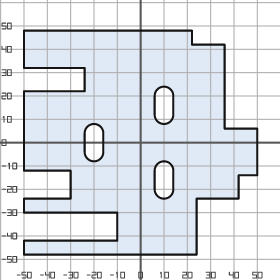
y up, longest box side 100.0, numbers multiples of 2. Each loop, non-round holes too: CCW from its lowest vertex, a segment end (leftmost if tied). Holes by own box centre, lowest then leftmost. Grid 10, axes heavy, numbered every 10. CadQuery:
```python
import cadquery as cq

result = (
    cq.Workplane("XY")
    .moveTo(-50.0, -48.0)
    .lineTo(24.0, -48.0)
    .lineTo(24.0, -24.0)
    .lineTo(42.0, -24.0)
    .lineTo(42.0, -14.0)
    .lineTo(50.0, -14.0)
    .lineTo(50.0, 6.0)
    .lineTo(36.0, 6.0)
    .lineTo(36.0, 42.0)
    .lineTo(22.0, 42.0)
    .lineTo(22.0, 48.0)
    .lineTo(-50.0, 48.0)
    .lineTo(-50.0, 32.0)
    .lineTo(-24.0, 32.0)
    .lineTo(-24.0, 22.0)
    .lineTo(-50.0, 22.0)
    .lineTo(-50.0, -12.0)
    .lineTo(-30.0, -12.0)
    .lineTo(-30.0, -24.0)
    .lineTo(-50.0, -24.0)
    .lineTo(-50.0, -30.0)
    .lineTo(-10.0, -30.0)
    .lineTo(-10.0, -42.0)
    .lineTo(-50.0, -42.0)
    .close()
    .moveTo(6.0, -20.0)
    .threePointArc((10.0, -24.0), (14.0, -20.0))
    .lineTo(14.0, -12.0)
    .threePointArc((10.0, -8.0), (6.0, -12.0))
    .close()
    .moveTo(-24.0, -4.0)
    .threePointArc((-20.0, -8.0), (-16.0, -4.0))
    .lineTo(-16.0, 4.0)
    .threePointArc((-20.0, 8.0), (-24.0, 4.0))
    .close()
    .moveTo(6.0, 12.0)
    .threePointArc((10.0, 8.0), (14.0, 12.0))
    .lineTo(14.0, 20.0)
    .threePointArc((10.0, 24.0), (6.0, 20.0))
    .close()
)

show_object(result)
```